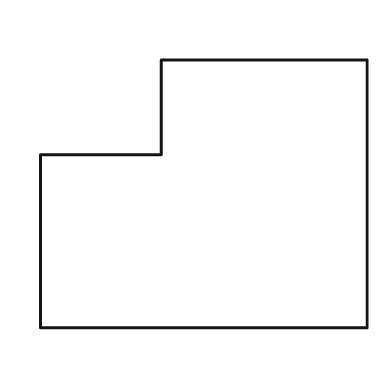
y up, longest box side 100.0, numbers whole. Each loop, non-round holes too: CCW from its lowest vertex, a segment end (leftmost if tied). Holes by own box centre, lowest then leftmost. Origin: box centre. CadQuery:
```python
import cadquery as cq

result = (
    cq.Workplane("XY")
    .moveTo(-50.0, -41.0)
    .lineTo(50.0, -41.0)
    .lineTo(50.0, 41.0)
    .lineTo(-13.0, 41.0)
    .lineTo(-13.0, 12.0)
    .lineTo(-50.0, 12.0)
    .close()
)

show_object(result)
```